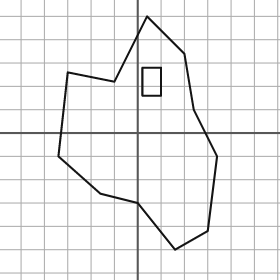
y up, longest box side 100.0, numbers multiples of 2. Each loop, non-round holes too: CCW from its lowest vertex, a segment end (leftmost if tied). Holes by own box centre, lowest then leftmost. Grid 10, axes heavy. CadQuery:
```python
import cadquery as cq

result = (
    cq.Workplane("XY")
    .moveTo(16.0, -50.0)
    .lineTo(30.0, -42.0)
    .lineTo(34.0, -10.0)
    .lineTo(24.0, 10.0)
    .lineTo(20.0, 34.0)
    .lineTo(4.0, 50.0)
    .lineTo(-10.0, 22.0)
    .lineTo(-30.0, 26.0)
    .lineTo(-34.0, -10.0)
    .lineTo(-16.0, -26.0)
    .lineTo(0.0, -30.0)
    .close()
    .moveTo(2.0, 16.0)
    .lineTo(10.0, 16.0)
    .lineTo(10.0, 28.0)
    .lineTo(2.0, 28.0)
    .close()
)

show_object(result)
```